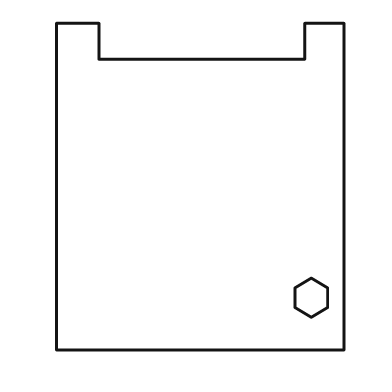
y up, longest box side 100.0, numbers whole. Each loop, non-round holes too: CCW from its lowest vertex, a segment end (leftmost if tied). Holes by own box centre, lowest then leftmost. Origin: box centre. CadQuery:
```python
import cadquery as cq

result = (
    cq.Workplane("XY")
    .moveTo(-44.0, -50.0)
    .lineTo(44.0, -50.0)
    .lineTo(44.0, 50.0)
    .lineTo(32.0, 50.0)
    .lineTo(32.0, 39.0)
    .lineTo(-31.0, 39.0)
    .lineTo(-31.0, 50.0)
    .lineTo(-44.0, 50.0)
    .close()
    .moveTo(34.0, -40.0)
    .lineTo(39.0, -37.0)
    .lineTo(39.0, -31.0)
    .lineTo(34.0, -28.0)
    .lineTo(29.0, -31.0)
    .lineTo(29.0, -37.0)
    .close()
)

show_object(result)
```